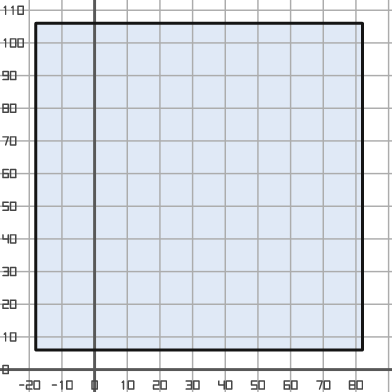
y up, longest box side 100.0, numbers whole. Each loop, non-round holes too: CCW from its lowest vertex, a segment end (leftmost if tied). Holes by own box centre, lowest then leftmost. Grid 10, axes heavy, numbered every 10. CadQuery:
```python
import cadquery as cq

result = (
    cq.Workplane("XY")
    .moveTo(-18.0, 6.0)
    .lineTo(82.0, 6.0)
    .lineTo(82.0, 106.0)
    .lineTo(-18.0, 106.0)
    .close()
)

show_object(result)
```